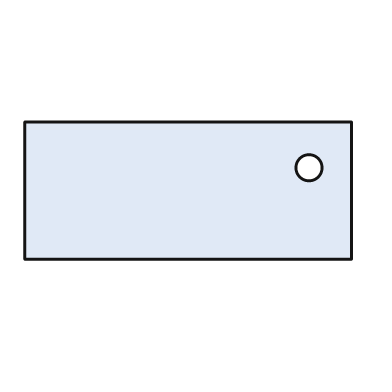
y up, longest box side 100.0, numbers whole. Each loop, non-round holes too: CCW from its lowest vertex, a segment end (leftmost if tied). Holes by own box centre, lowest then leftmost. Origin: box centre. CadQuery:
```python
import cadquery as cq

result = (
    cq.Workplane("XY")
    .moveTo(-50.0, -21.0)
    .lineTo(50.0, -21.0)
    .lineTo(50.0, 21.0)
    .lineTo(-50.0, 21.0)
    .close()
    .moveTo(37.0, 7.0)
    .circle(4.0)
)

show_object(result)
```